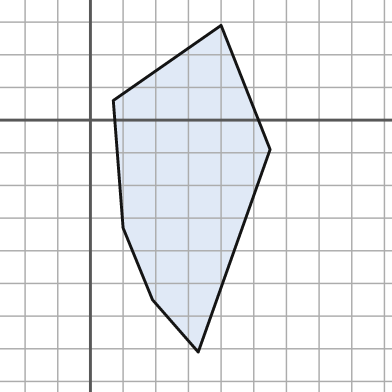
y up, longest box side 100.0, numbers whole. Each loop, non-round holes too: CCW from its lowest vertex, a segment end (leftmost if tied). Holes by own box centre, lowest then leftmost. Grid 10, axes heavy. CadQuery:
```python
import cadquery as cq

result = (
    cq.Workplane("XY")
    .moveTo(33.0, -71.0)
    .lineTo(55.0, -9.0)
    .lineTo(40.0, 29.0)
    .lineTo(7.0, 6.0)
    .lineTo(10.0, -33.0)
    .lineTo(19.0, -55.0)
    .close()
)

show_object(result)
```